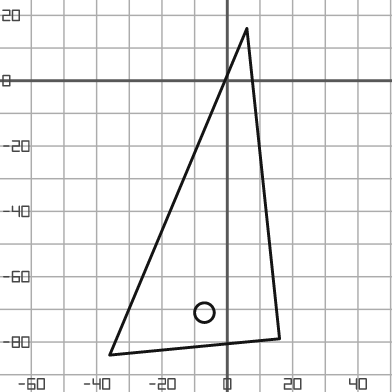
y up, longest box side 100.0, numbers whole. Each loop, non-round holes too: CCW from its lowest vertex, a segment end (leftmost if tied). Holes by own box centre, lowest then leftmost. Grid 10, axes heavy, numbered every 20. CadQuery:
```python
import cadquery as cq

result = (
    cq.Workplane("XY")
    .moveTo(-36.0, -84.0)
    .lineTo(16.0, -79.0)
    .lineTo(6.0, 16.0)
    .close()
    .moveTo(-7.0, -71.0)
    .circle(3.0)
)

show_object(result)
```